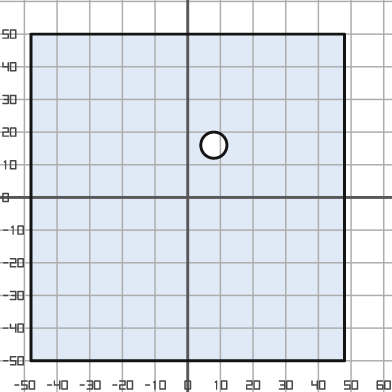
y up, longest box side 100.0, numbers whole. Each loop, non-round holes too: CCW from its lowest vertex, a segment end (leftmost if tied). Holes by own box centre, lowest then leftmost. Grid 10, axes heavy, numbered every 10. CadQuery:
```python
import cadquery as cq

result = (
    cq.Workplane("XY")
    .moveTo(-48.0, -50.0)
    .lineTo(48.0, -50.0)
    .lineTo(48.0, 50.0)
    .lineTo(-48.0, 50.0)
    .close()
    .moveTo(8.0, 16.0)
    .circle(4.0)
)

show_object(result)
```